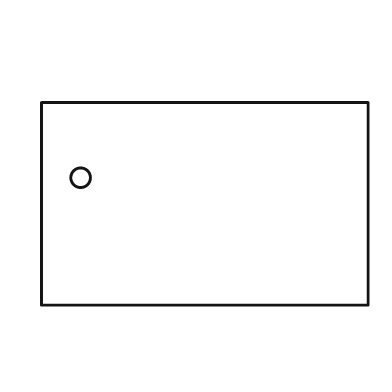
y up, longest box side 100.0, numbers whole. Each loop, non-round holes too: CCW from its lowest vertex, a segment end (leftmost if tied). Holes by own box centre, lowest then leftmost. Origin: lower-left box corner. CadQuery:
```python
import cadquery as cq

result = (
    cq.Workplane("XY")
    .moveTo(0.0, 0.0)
    .lineTo(100.0, 0.0)
    .lineTo(100.0, 62.0)
    .lineTo(0.0, 62.0)
    .close()
    .moveTo(12.0, 39.0)
    .circle(3.0)
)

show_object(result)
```